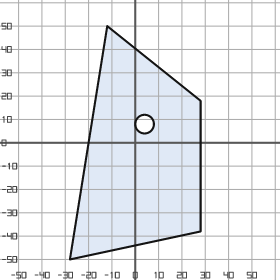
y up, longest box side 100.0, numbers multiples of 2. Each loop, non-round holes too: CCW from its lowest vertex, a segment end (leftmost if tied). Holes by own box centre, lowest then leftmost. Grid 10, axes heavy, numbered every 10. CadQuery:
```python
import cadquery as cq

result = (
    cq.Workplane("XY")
    .moveTo(-28.0, -50.0)
    .lineTo(28.0, -38.0)
    .lineTo(28.0, 18.0)
    .lineTo(-12.0, 50.0)
    .close()
    .moveTo(4.0, 8.0)
    .circle(4.0)
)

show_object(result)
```